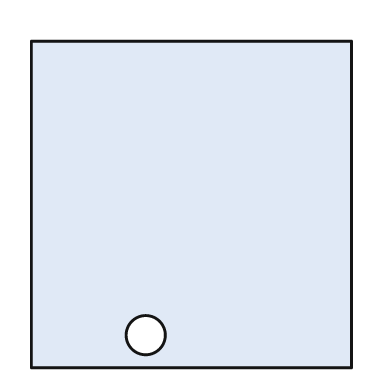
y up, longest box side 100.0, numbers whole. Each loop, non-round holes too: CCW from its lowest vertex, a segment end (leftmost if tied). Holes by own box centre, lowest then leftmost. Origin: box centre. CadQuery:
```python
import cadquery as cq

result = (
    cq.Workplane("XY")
    .moveTo(-49.0, -50.0)
    .lineTo(49.0, -50.0)
    .lineTo(49.0, 50.0)
    .lineTo(-49.0, 50.0)
    .close()
    .moveTo(-14.0, -40.0)
    .circle(6.0)
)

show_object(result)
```